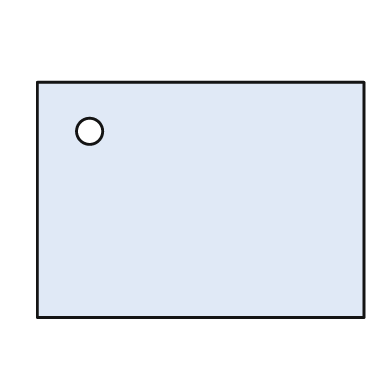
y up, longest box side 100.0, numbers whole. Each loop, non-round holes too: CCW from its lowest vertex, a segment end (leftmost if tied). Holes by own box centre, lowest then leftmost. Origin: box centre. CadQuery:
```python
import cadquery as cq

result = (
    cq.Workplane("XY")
    .moveTo(-50.0, -36.0)
    .lineTo(50.0, -36.0)
    .lineTo(50.0, 36.0)
    .lineTo(-50.0, 36.0)
    .close()
    .moveTo(-34.0, 21.0)
    .circle(4.0)
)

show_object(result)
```